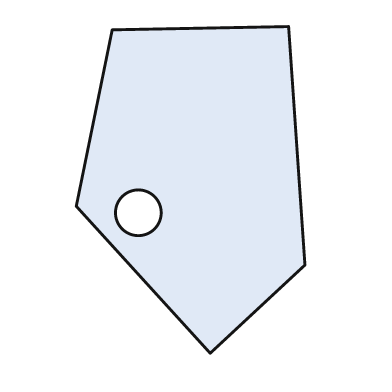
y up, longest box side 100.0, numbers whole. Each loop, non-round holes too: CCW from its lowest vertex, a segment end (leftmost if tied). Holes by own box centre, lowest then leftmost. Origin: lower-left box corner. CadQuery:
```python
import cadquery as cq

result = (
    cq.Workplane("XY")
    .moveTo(41.0, 0.0)
    .lineTo(70.0, 27.0)
    .lineTo(65.0, 100.0)
    .lineTo(11.0, 99.0)
    .lineTo(0.0, 45.0)
    .close()
    .moveTo(19.0, 43.0)
    .circle(7.0)
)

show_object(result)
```